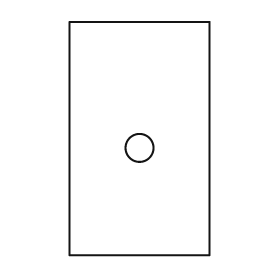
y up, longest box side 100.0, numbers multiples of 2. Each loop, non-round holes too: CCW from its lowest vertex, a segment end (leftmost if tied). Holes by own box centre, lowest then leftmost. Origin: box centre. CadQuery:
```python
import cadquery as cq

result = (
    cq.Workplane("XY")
    .moveTo(-30.0, -50.0)
    .lineTo(30.0, -50.0)
    .lineTo(30.0, 50.0)
    .lineTo(-30.0, 50.0)
    .close()
    .moveTo(0.0, -4.0)
    .circle(6.0)
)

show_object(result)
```